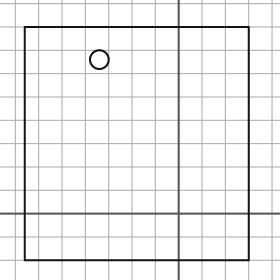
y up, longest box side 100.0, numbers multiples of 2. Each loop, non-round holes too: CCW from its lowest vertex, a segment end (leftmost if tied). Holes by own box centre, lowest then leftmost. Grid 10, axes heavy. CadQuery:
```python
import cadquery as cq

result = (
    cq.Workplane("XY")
    .moveTo(-66.0, -20.0)
    .lineTo(30.0, -20.0)
    .lineTo(30.0, 80.0)
    .lineTo(-66.0, 80.0)
    .close()
    .moveTo(-34.0, 66.0)
    .circle(4.0)
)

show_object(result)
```